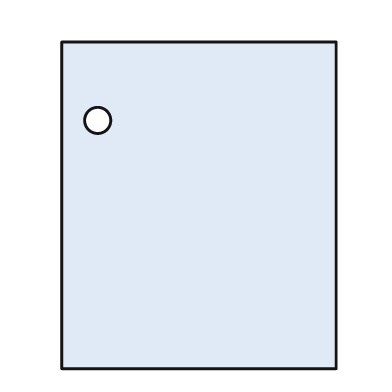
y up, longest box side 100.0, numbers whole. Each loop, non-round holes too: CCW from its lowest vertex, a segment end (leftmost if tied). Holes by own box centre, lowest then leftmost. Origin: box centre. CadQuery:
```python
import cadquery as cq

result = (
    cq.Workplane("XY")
    .moveTo(-42.0, -50.0)
    .lineTo(42.0, -50.0)
    .lineTo(42.0, 50.0)
    .lineTo(-42.0, 50.0)
    .close()
    .moveTo(-31.0, 26.0)
    .circle(4.0)
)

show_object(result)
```